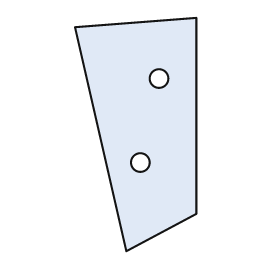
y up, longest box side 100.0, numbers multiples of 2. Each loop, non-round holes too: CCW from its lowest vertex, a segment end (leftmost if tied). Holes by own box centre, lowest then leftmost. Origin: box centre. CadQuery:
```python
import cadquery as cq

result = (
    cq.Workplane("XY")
    .moveTo(-4.0, -50.0)
    .lineTo(26.0, -34.0)
    .lineTo(26.0, 50.0)
    .lineTo(-26.0, 46.0)
    .close()
    .moveTo(2.0, -12.0)
    .circle(4.0)
    .moveTo(10.0, 24.0)
    .circle(4.0)
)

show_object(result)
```